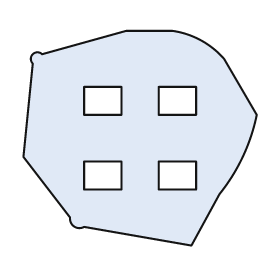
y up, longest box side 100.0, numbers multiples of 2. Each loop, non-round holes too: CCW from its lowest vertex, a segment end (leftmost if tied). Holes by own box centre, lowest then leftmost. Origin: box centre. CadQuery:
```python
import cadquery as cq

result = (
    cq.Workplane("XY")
    .moveTo(22.0, -46.0)
    .lineTo(34.0, -24.0)
    .threePointArc((44.0, -8.0), (50.0, 10.0))
    .lineTo(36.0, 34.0)
    .threePointArc((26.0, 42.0), (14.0, 46.0))
    .lineTo(-6.0, 46.0)
    .lineTo(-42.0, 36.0)
    .threePointArc((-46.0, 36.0), (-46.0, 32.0))
    .lineTo(-50.0, -8.0)
    .lineTo(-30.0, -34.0)
    .threePointArc((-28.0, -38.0), (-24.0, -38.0))
    .close()
    .moveTo(-24.0, -22.0)
    .lineTo(-8.0, -22.0)
    .lineTo(-8.0, -10.0)
    .lineTo(-24.0, -10.0)
    .close()
    .moveTo(8.0, -22.0)
    .lineTo(24.0, -22.0)
    .lineTo(24.0, -10.0)
    .lineTo(8.0, -10.0)
    .close()
    .moveTo(-24.0, 10.0)
    .lineTo(-8.0, 10.0)
    .lineTo(-8.0, 22.0)
    .lineTo(-24.0, 22.0)
    .close()
    .moveTo(8.0, 10.0)
    .lineTo(24.0, 10.0)
    .lineTo(24.0, 22.0)
    .lineTo(8.0, 22.0)
    .close()
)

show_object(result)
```